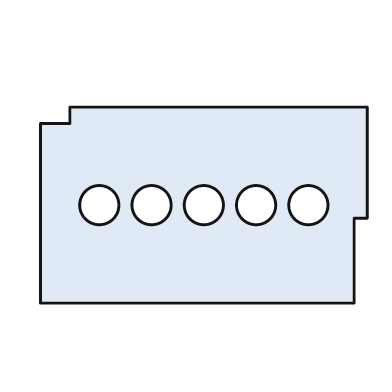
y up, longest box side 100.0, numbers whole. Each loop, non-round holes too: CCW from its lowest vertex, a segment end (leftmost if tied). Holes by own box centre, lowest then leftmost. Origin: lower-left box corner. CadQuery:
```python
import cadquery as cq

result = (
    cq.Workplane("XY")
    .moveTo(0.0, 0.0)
    .lineTo(96.0, 0.0)
    .lineTo(96.0, 26.0)
    .lineTo(100.0, 26.0)
    .lineTo(100.0, 60.0)
    .lineTo(9.0, 60.0)
    .lineTo(9.0, 55.0)
    .lineTo(0.0, 55.0)
    .close()
    .moveTo(18.0, 30.0)
    .circle(6.0)
    .moveTo(34.0, 30.0)
    .circle(6.0)
    .moveTo(50.0, 30.0)
    .circle(6.0)
    .moveTo(66.0, 30.0)
    .circle(6.0)
    .moveTo(82.0, 30.0)
    .circle(6.0)
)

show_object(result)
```